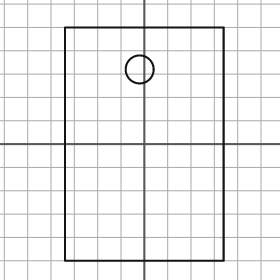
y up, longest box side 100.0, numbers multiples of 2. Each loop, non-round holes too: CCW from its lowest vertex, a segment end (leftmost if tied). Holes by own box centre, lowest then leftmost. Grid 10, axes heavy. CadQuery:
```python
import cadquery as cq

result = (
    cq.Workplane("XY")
    .moveTo(-34.0, -50.0)
    .lineTo(34.0, -50.0)
    .lineTo(34.0, 50.0)
    .lineTo(-34.0, 50.0)
    .close()
    .moveTo(-2.0, 32.0)
    .circle(6.0)
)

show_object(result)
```